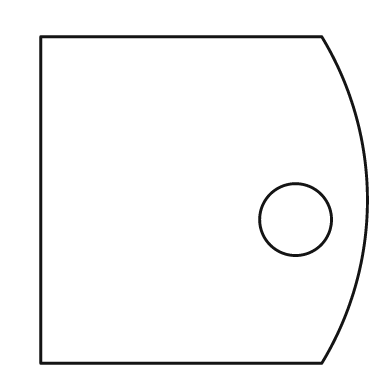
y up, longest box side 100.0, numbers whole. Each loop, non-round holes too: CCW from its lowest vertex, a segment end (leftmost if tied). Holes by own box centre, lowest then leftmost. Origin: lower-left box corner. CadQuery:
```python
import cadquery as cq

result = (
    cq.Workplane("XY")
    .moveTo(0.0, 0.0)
    .lineTo(86.0, 0.0)
    .threePointArc((100.0, 50.0), (86.0, 100.0))
    .lineTo(0.0, 100.0)
    .close()
    .moveTo(78.0, 44.0)
    .circle(11.0)
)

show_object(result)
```